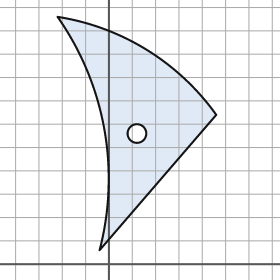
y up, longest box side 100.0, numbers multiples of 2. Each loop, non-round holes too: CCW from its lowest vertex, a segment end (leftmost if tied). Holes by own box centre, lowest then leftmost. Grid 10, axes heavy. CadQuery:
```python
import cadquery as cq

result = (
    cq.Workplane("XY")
    .moveTo(-4.0, 6.0)
    .lineTo(46.0, 64.0)
    .threePointArc((16.0, 92.0), (-22.0, 106.0))
    .threePointArc((-2.0, 58.0), (-4.0, 6.0))
    .close()
    .moveTo(12.0, 56.0)
    .circle(4.0)
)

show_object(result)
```